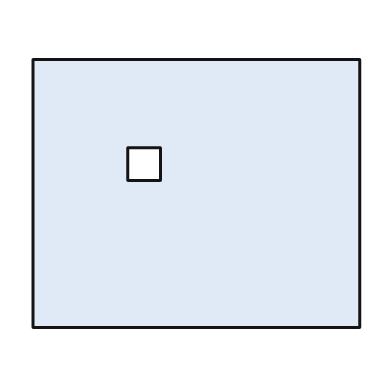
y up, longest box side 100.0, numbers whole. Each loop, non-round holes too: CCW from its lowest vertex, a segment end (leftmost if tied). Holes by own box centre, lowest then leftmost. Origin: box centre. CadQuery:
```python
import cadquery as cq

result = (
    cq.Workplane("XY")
    .moveTo(-50.0, -41.0)
    .lineTo(50.0, -41.0)
    .lineTo(50.0, 41.0)
    .lineTo(-50.0, 41.0)
    .close()
    .moveTo(-21.0, 4.0)
    .lineTo(-11.0, 4.0)
    .lineTo(-11.0, 14.0)
    .lineTo(-21.0, 14.0)
    .close()
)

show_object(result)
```